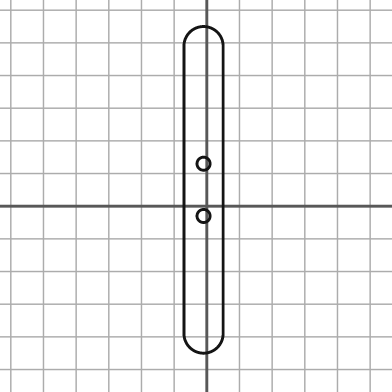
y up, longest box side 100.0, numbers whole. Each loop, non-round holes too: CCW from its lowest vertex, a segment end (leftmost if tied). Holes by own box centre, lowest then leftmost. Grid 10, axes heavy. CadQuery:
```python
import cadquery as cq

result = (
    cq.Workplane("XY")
    .moveTo(-7.0, -39.0)
    .threePointArc((-1.0, -45.0), (5.0, -39.0))
    .lineTo(5.0, 49.0)
    .threePointArc((-1.0, 55.0), (-7.0, 49.0))
    .close()
    .moveTo(-1.0, -3.0)
    .circle(2.0)
    .moveTo(-1.0, 13.0)
    .circle(2.0)
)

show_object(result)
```